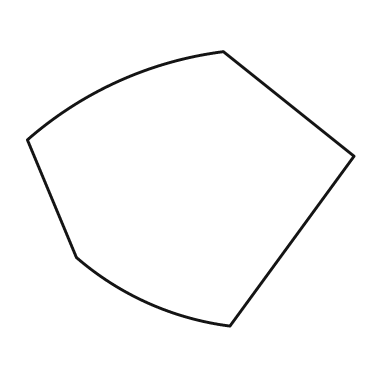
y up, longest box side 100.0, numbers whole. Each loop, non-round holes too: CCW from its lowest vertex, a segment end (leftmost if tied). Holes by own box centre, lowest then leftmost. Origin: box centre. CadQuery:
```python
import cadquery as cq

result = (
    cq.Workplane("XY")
    .moveTo(12.0, -42.0)
    .lineTo(50.0, 10.0)
    .lineTo(10.0, 42.0)
    .threePointArc((-22.0, 33.0), (-50.0, 15.0))
    .lineTo(-35.0, -21.0)
    .threePointArc((-13.0, -35.0), (12.0, -42.0))
    .close()
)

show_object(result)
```